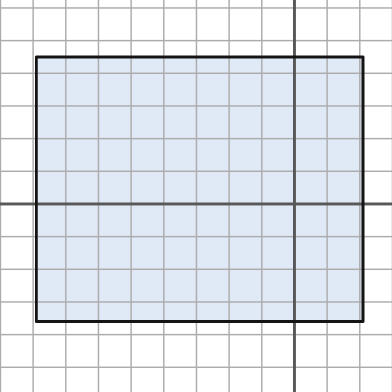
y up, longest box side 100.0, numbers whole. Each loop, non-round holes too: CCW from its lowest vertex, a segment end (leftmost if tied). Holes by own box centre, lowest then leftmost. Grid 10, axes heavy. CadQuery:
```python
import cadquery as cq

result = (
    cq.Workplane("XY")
    .moveTo(-79.0, -36.0)
    .lineTo(21.0, -36.0)
    .lineTo(21.0, 45.0)
    .lineTo(-79.0, 45.0)
    .close()
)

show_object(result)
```